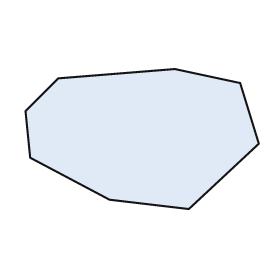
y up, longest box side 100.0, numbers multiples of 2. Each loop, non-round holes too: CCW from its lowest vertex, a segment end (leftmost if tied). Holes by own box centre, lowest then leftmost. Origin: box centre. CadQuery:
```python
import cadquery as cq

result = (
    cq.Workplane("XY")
    .moveTo(20.0, -30.0)
    .lineTo(50.0, -2.0)
    .lineTo(42.0, 24.0)
    .lineTo(14.0, 30.0)
    .lineTo(-36.0, 26.0)
    .lineTo(-50.0, 12.0)
    .lineTo(-48.0, -8.0)
    .lineTo(-14.0, -26.0)
    .close()
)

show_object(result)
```